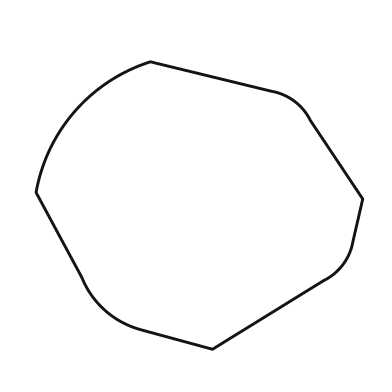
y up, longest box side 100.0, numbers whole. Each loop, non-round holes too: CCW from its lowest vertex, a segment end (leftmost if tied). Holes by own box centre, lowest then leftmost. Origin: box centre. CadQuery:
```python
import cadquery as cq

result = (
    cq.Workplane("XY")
    .moveTo(4.0, -44.0)
    .lineTo(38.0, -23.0)
    .threePointArc((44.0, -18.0), (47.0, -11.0))
    .lineTo(50.0, 2.0)
    .lineTo(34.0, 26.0)
    .threePointArc((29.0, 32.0), (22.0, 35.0))
    .lineTo(-15.0, 44.0)
    .threePointArc((-38.0, 29.0), (-50.0, 4.0))
    .lineTo(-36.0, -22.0)
    .threePointArc((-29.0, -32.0), (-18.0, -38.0))
    .close()
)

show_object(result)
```